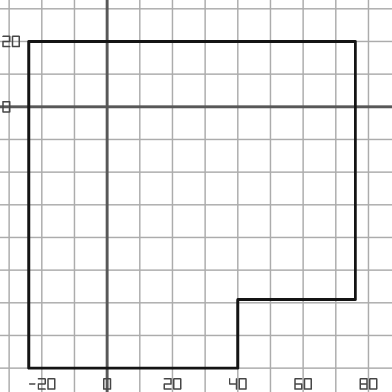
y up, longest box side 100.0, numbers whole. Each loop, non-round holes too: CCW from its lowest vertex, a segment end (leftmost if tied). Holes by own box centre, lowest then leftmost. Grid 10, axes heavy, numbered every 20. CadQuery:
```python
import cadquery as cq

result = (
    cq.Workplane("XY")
    .moveTo(-24.0, -80.0)
    .lineTo(40.0, -80.0)
    .lineTo(40.0, -59.0)
    .lineTo(76.0, -59.0)
    .lineTo(76.0, 20.0)
    .lineTo(-24.0, 20.0)
    .close()
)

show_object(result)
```